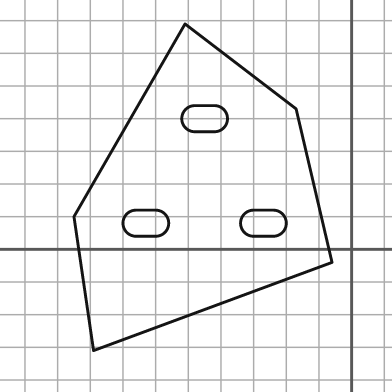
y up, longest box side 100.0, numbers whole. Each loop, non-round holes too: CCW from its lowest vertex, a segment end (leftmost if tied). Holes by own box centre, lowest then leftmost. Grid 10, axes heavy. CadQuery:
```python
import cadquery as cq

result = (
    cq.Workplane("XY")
    .moveTo(-79.0, -31.0)
    .lineTo(-6.0, -4.0)
    .lineTo(-17.0, 43.0)
    .lineTo(-51.0, 69.0)
    .lineTo(-85.0, 10.0)
    .close()
    .moveTo(-66.0, 4.0)
    .lineTo(-60.0, 4.0)
    .threePointArc((-56.0, 8.0), (-60.0, 12.0))
    .lineTo(-66.0, 12.0)
    .threePointArc((-70.0, 8.0), (-66.0, 4.0))
    .close()
    .moveTo(-30.0, 4.0)
    .lineTo(-24.0, 4.0)
    .threePointArc((-20.0, 8.0), (-24.0, 12.0))
    .lineTo(-30.0, 12.0)
    .threePointArc((-34.0, 8.0), (-30.0, 4.0))
    .close()
    .moveTo(-48.0, 36.0)
    .lineTo(-42.0, 36.0)
    .threePointArc((-38.0, 40.0), (-42.0, 44.0))
    .lineTo(-48.0, 44.0)
    .threePointArc((-52.0, 40.0), (-48.0, 36.0))
    .close()
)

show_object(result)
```